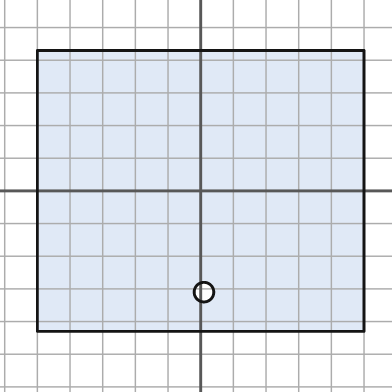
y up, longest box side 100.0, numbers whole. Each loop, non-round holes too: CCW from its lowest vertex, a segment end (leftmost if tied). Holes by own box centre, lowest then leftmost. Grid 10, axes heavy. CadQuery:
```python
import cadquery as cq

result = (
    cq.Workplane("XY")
    .moveTo(-50.0, -43.0)
    .lineTo(50.0, -43.0)
    .lineTo(50.0, 43.0)
    .lineTo(-50.0, 43.0)
    .close()
    .moveTo(1.0, -31.0)
    .circle(3.0)
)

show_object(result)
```